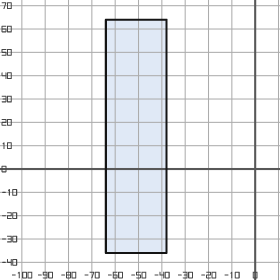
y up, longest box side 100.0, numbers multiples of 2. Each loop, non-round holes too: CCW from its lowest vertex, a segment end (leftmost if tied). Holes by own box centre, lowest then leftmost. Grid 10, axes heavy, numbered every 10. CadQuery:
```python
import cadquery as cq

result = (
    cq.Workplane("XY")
    .moveTo(-64.0, -36.0)
    .lineTo(-38.0, -36.0)
    .lineTo(-38.0, 64.0)
    .lineTo(-64.0, 64.0)
    .close()
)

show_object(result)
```